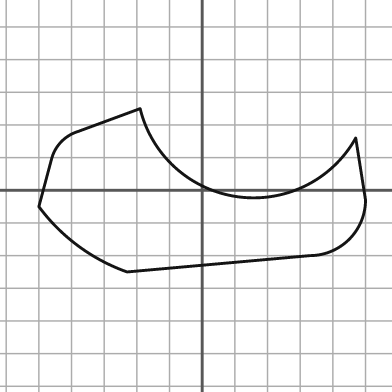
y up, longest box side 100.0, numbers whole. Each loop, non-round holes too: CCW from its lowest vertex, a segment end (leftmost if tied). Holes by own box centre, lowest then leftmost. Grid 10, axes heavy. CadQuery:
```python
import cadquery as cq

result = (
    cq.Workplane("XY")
    .moveTo(-23.0, -25.0)
    .lineTo(33.0, -20.0)
    .threePointArc((45.0, -15.0), (50.0, -3.0))
    .lineTo(47.0, 16.0)
    .threePointArc((11.0, -2.0), (-19.0, 25.0))
    .lineTo(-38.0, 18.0)
    .threePointArc((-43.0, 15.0), (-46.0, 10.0))
    .lineTo(-50.0, -5.0)
    .threePointArc((-38.0, -17.0), (-23.0, -25.0))
    .close()
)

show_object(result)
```